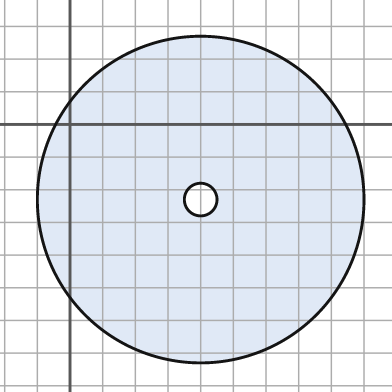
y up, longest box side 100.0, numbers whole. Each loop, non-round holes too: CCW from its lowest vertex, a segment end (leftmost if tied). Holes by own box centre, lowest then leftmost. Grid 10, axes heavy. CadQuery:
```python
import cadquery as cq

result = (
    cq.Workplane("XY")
    .moveTo(40.0, -23.0)
    .circle(50.0)
    .moveTo(40.0, -23.0)
    .circle(5.0)
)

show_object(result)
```